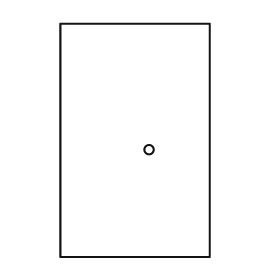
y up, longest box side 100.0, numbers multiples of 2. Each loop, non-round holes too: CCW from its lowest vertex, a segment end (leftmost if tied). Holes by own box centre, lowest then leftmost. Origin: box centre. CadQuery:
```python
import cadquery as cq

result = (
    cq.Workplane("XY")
    .moveTo(-32.0, -50.0)
    .lineTo(32.0, -50.0)
    .lineTo(32.0, 50.0)
    .lineTo(-32.0, 50.0)
    .close()
    .moveTo(6.0, -4.0)
    .circle(2.0)
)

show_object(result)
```